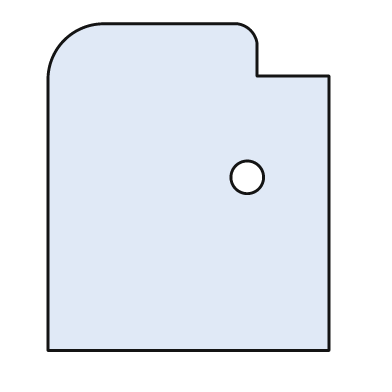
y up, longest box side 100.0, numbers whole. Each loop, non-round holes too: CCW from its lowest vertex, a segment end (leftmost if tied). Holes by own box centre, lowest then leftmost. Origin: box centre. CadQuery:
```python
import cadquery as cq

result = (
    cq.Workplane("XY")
    .moveTo(-43.0, -50.0)
    .lineTo(43.0, -50.0)
    .lineTo(43.0, 34.0)
    .lineTo(21.0, 34.0)
    .lineTo(21.0, 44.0)
    .threePointArc((19.0, 48.0), (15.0, 50.0))
    .lineTo(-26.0, 50.0)
    .threePointArc((-38.0, 45.0), (-43.0, 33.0))
    .close()
    .moveTo(18.0, 3.0)
    .circle(5.0)
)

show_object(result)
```